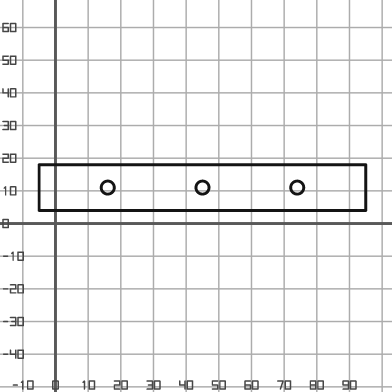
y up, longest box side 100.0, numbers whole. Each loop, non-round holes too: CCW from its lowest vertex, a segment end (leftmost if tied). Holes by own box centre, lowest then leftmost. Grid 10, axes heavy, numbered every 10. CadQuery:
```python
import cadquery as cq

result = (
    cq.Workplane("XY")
    .moveTo(-5.0, 4.0)
    .lineTo(95.0, 4.0)
    .lineTo(95.0, 18.0)
    .lineTo(-5.0, 18.0)
    .close()
    .moveTo(16.0, 11.0)
    .circle(2.0)
    .moveTo(45.0, 11.0)
    .circle(2.0)
    .moveTo(74.0, 11.0)
    .circle(2.0)
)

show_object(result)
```